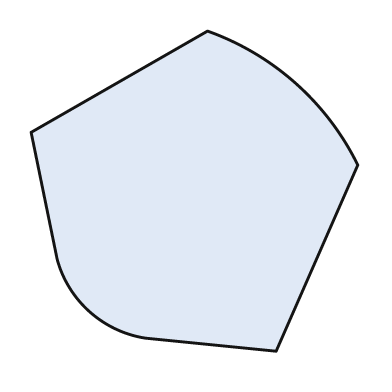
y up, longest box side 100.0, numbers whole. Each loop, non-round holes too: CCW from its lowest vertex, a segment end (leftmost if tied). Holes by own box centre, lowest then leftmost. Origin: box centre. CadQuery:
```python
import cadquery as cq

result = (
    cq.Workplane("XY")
    .moveTo(25.0, -49.0)
    .lineTo(50.0, 8.0)
    .threePointArc((31.0, 33.0), (4.0, 49.0))
    .lineTo(-50.0, 18.0)
    .lineTo(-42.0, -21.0)
    .threePointArc((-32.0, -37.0), (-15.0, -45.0))
    .close()
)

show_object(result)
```